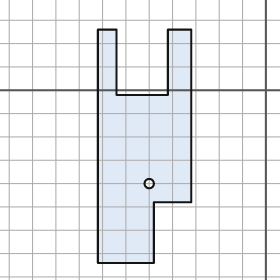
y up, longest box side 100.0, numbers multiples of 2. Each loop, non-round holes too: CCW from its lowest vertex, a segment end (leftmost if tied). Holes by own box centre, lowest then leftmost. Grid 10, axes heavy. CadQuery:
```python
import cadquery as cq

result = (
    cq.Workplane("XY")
    .moveTo(-72.0, -74.0)
    .lineTo(-48.0, -74.0)
    .lineTo(-48.0, -48.0)
    .lineTo(-32.0, -48.0)
    .lineTo(-32.0, 26.0)
    .lineTo(-42.0, 26.0)
    .lineTo(-42.0, -2.0)
    .lineTo(-64.0, -2.0)
    .lineTo(-64.0, 26.0)
    .lineTo(-72.0, 26.0)
    .close()
    .moveTo(-50.0, -40.0)
    .circle(2.0)
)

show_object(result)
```